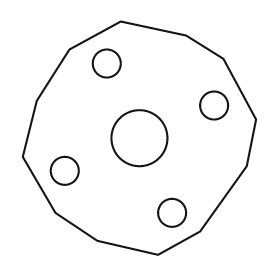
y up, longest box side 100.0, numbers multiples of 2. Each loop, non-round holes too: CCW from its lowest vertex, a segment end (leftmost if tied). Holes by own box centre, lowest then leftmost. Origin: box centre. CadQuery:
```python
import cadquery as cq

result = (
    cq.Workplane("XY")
    .moveTo(8.0, -50.0)
    .lineTo(26.0, -40.0)
    .lineTo(46.0, -12.0)
    .lineTo(50.0, 8.0)
    .lineTo(36.0, 34.0)
    .lineTo(20.0, 44.0)
    .lineTo(-8.0, 50.0)
    .lineTo(-30.0, 38.0)
    .lineTo(-44.0, 16.0)
    .lineTo(-50.0, -8.0)
    .lineTo(-36.0, -32.0)
    .lineTo(-18.0, -44.0)
    .close()
    .moveTo(14.0, -32.0)
    .circle(6.0)
    .moveTo(-32.0, -14.0)
    .circle(6.0)
    .moveTo(0.0, 0.0)
    .circle(12.0)
    .moveTo(32.0, 14.0)
    .circle(6.0)
    .moveTo(-14.0, 32.0)
    .circle(6.0)
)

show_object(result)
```